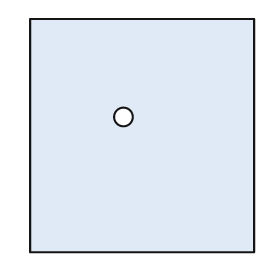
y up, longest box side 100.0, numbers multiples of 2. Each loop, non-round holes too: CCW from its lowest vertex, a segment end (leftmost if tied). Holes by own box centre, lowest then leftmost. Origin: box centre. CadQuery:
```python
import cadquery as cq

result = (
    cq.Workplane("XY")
    .moveTo(-48.0, -50.0)
    .lineTo(48.0, -50.0)
    .lineTo(48.0, 50.0)
    .lineTo(-48.0, 50.0)
    .close()
    .moveTo(-8.0, 8.0)
    .circle(4.0)
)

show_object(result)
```